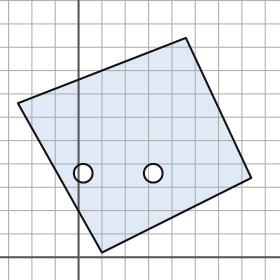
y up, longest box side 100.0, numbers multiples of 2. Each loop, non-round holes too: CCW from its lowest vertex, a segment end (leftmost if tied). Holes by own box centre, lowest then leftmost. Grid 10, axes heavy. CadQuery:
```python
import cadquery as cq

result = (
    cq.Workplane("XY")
    .moveTo(10.0, 2.0)
    .lineTo(74.0, 34.0)
    .lineTo(46.0, 94.0)
    .lineTo(-26.0, 66.0)
    .close()
    .moveTo(2.0, 36.0)
    .circle(4.0)
    .moveTo(32.0, 36.0)
    .circle(4.0)
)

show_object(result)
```